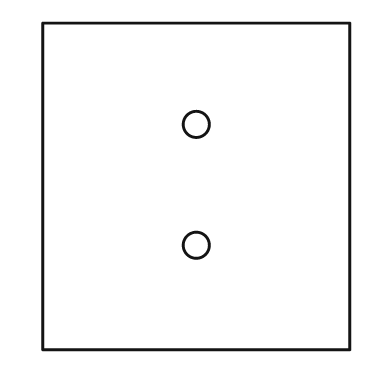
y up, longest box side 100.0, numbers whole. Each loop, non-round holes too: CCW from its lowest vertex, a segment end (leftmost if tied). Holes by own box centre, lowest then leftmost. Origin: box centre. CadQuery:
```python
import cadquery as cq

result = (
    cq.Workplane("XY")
    .moveTo(-47.0, -50.0)
    .lineTo(47.0, -50.0)
    .lineTo(47.0, 50.0)
    .lineTo(-47.0, 50.0)
    .close()
    .moveTo(0.0, -18.0)
    .circle(4.0)
    .moveTo(0.0, 19.0)
    .circle(4.0)
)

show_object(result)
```